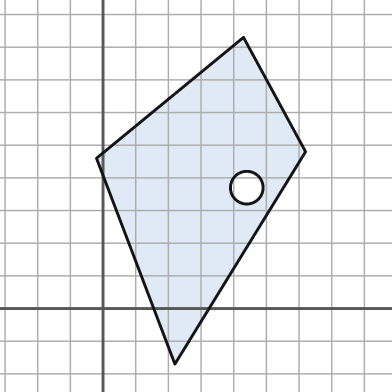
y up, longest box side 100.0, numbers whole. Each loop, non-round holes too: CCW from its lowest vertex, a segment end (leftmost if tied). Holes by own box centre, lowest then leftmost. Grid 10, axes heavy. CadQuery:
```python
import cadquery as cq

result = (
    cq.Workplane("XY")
    .moveTo(22.0, -17.0)
    .lineTo(62.0, 48.0)
    .lineTo(43.0, 83.0)
    .lineTo(-2.0, 46.0)
    .close()
    .moveTo(44.0, 37.0)
    .circle(5.0)
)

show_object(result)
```